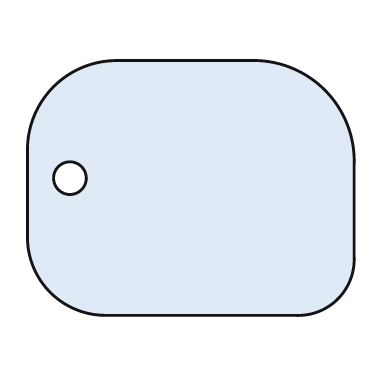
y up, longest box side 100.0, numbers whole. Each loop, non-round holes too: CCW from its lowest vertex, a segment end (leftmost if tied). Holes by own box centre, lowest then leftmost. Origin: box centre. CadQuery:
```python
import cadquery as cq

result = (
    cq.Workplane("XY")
    .moveTo(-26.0, -39.0)
    .lineTo(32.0, -39.0)
    .threePointArc((45.0, -34.0), (50.0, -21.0))
    .lineTo(50.0, 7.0)
    .threePointArc((41.0, 30.0), (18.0, 39.0))
    .lineTo(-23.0, 39.0)
    .threePointArc((-42.0, 31.0), (-50.0, 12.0))
    .lineTo(-50.0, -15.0)
    .threePointArc((-43.0, -32.0), (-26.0, -39.0))
    .close()
    .moveTo(-37.0, 3.0)
    .circle(5.0)
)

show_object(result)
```